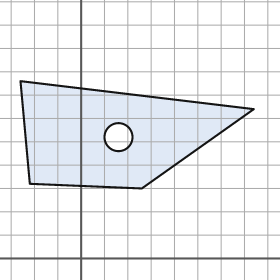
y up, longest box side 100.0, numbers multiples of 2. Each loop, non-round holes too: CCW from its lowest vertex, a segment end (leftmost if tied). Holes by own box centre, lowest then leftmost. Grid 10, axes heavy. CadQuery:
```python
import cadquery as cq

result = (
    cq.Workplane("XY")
    .moveTo(26.0, 30.0)
    .lineTo(74.0, 64.0)
    .lineTo(-26.0, 76.0)
    .lineTo(-22.0, 32.0)
    .close()
    .moveTo(16.0, 52.0)
    .circle(6.0)
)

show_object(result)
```